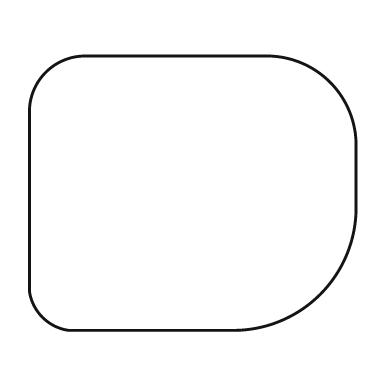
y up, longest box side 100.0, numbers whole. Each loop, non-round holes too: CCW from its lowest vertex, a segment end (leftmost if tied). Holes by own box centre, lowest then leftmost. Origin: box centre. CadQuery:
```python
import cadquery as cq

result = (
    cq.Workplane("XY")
    .moveTo(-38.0, -42.0)
    .lineTo(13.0, -42.0)
    .threePointArc((39.0, -31.0), (50.0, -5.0))
    .lineTo(50.0, 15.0)
    .threePointArc((42.0, 34.0), (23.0, 42.0))
    .lineTo(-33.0, 42.0)
    .threePointArc((-45.0, 37.0), (-50.0, 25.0))
    .lineTo(-50.0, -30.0)
    .threePointArc((-46.0, -38.0), (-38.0, -42.0))
    .close()
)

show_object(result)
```